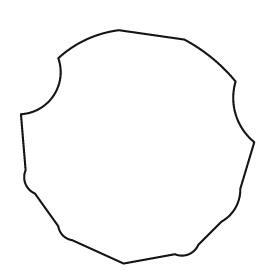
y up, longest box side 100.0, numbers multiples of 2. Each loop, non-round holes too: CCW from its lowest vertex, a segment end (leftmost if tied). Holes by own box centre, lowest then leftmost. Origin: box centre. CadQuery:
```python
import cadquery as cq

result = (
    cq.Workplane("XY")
    .moveTo(-6.0, -50.0)
    .lineTo(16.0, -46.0)
    .threePointArc((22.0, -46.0), (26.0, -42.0))
    .lineTo(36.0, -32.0)
    .threePointArc((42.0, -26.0), (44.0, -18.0))
    .lineTo(50.0, 2.0)
    .threePointArc((42.0, 14.0), (42.0, 28.0))
    .threePointArc((32.0, 38.0), (20.0, 46.0))
    .lineTo(-8.0, 50.0)
    .threePointArc((-22.0, 46.0), (-34.0, 38.0))
    .threePointArc((-36.0, 22.0), (-50.0, 14.0))
    .lineTo(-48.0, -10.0)
    .threePointArc((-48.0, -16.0), (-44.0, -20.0))
    .lineTo(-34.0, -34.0)
    .threePointArc((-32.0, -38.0), (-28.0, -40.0))
    .close()
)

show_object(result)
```